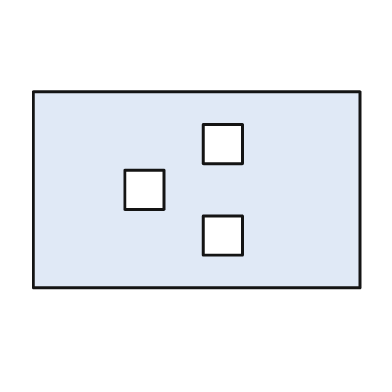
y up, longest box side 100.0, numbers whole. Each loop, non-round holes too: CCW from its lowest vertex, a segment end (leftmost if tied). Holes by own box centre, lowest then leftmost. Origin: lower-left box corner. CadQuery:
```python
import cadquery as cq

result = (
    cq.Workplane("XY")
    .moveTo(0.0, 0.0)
    .lineTo(100.0, 0.0)
    .lineTo(100.0, 60.0)
    .lineTo(0.0, 60.0)
    .close()
    .moveTo(52.0, 10.0)
    .lineTo(64.0, 10.0)
    .lineTo(64.0, 22.0)
    .lineTo(52.0, 22.0)
    .close()
    .moveTo(28.0, 24.0)
    .lineTo(40.0, 24.0)
    .lineTo(40.0, 36.0)
    .lineTo(28.0, 36.0)
    .close()
    .moveTo(52.0, 38.0)
    .lineTo(64.0, 38.0)
    .lineTo(64.0, 50.0)
    .lineTo(52.0, 50.0)
    .close()
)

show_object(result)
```